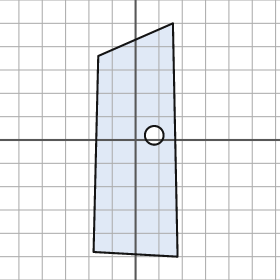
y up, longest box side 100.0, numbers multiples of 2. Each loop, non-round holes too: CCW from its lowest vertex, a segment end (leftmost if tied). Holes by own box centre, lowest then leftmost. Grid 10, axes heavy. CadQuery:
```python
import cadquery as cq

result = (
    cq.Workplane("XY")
    .moveTo(18.0, -50.0)
    .lineTo(16.0, 50.0)
    .lineTo(-16.0, 36.0)
    .lineTo(-18.0, -48.0)
    .close()
    .moveTo(8.0, 2.0)
    .circle(4.0)
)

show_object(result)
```